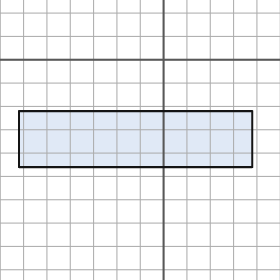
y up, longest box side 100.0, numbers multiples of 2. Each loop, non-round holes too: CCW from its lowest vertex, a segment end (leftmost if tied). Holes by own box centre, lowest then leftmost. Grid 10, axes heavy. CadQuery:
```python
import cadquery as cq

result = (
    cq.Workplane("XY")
    .moveTo(-62.0, -46.0)
    .lineTo(38.0, -46.0)
    .lineTo(38.0, -22.0)
    .lineTo(-62.0, -22.0)
    .close()
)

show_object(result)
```